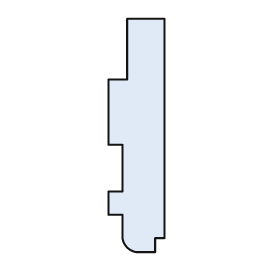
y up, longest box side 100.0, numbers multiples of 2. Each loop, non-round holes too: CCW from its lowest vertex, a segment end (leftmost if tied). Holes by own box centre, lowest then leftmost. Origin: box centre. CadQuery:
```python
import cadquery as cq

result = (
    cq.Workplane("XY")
    .moveTo(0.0, -50.0)
    .lineTo(8.0, -50.0)
    .lineTo(8.0, -44.0)
    .lineTo(12.0, -44.0)
    .lineTo(12.0, 50.0)
    .lineTo(-4.0, 50.0)
    .lineTo(-4.0, 24.0)
    .lineTo(-12.0, 24.0)
    .lineTo(-12.0, -4.0)
    .lineTo(-6.0, -4.0)
    .lineTo(-6.0, -24.0)
    .lineTo(-12.0, -24.0)
    .lineTo(-12.0, -34.0)
    .lineTo(-6.0, -34.0)
    .lineTo(-6.0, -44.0)
    .threePointArc((-4.0, -48.0), (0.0, -50.0))
    .close()
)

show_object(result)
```